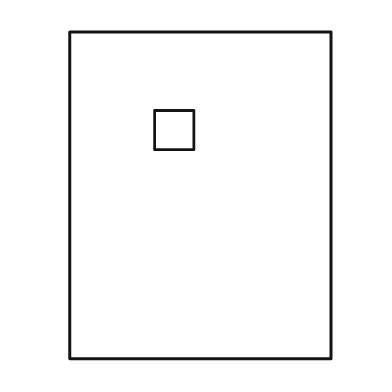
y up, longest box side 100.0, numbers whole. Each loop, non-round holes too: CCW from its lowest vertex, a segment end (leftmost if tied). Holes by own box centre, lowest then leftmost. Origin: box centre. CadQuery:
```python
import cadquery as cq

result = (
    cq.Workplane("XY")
    .moveTo(-40.0, -50.0)
    .lineTo(40.0, -50.0)
    .lineTo(40.0, 50.0)
    .lineTo(-40.0, 50.0)
    .close()
    .moveTo(-14.0, 14.0)
    .lineTo(-2.0, 14.0)
    .lineTo(-2.0, 26.0)
    .lineTo(-14.0, 26.0)
    .close()
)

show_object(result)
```